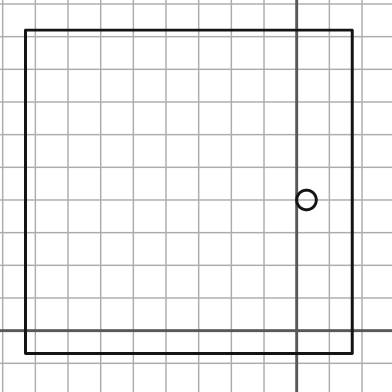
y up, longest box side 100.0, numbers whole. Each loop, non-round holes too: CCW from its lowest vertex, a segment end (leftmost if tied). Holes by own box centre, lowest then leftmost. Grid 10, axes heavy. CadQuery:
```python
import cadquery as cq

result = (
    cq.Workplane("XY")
    .moveTo(-83.0, -7.0)
    .lineTo(17.0, -7.0)
    .lineTo(17.0, 92.0)
    .lineTo(-83.0, 92.0)
    .close()
    .moveTo(3.0, 40.0)
    .circle(3.0)
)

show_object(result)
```